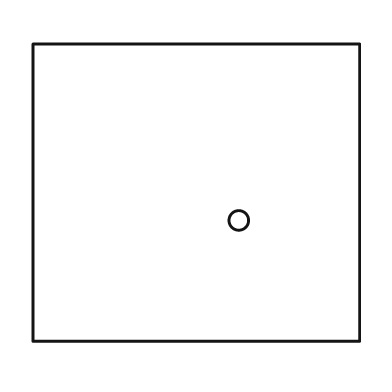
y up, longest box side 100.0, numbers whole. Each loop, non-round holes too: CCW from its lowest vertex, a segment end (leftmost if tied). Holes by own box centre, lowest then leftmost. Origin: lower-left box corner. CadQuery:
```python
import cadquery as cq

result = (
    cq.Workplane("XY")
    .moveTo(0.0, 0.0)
    .lineTo(100.0, 0.0)
    .lineTo(100.0, 91.0)
    .lineTo(0.0, 91.0)
    .close()
    .moveTo(63.0, 37.0)
    .circle(3.0)
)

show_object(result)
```